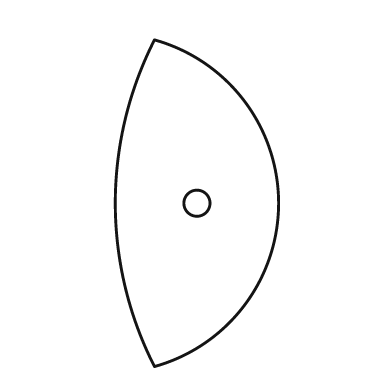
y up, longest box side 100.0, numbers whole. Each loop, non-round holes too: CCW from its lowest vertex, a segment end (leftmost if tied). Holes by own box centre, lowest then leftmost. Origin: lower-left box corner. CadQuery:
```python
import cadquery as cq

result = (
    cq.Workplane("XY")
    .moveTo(12.0, 0.0)
    .threePointArc((50.0, 50.0), (12.0, 100.0))
    .threePointArc((0.0, 50.0), (12.0, 0.0))
    .close()
    .moveTo(25.0, 50.0)
    .circle(4.0)
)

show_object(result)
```